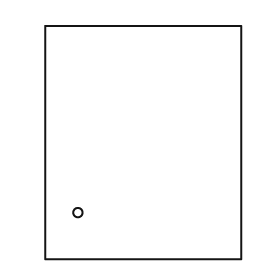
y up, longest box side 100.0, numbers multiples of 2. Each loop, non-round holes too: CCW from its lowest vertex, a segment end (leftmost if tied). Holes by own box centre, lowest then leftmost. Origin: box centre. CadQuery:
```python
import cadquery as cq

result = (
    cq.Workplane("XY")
    .moveTo(-42.0, -50.0)
    .lineTo(42.0, -50.0)
    .lineTo(42.0, 50.0)
    .lineTo(-42.0, 50.0)
    .close()
    .moveTo(-28.0, -30.0)
    .circle(2.0)
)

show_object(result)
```